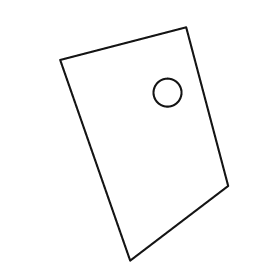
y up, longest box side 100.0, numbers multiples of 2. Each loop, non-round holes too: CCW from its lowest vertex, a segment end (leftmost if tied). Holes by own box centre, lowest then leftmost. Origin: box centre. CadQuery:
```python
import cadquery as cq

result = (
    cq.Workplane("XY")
    .moveTo(-6.0, -50.0)
    .lineTo(36.0, -18.0)
    .lineTo(18.0, 50.0)
    .lineTo(-36.0, 36.0)
    .close()
    .moveTo(10.0, 22.0)
    .circle(6.0)
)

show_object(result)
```